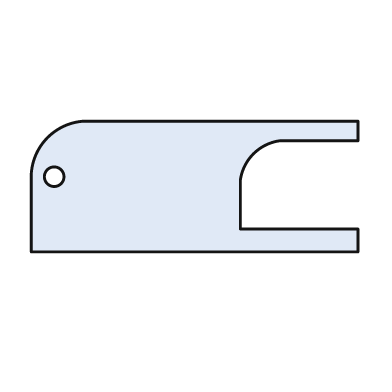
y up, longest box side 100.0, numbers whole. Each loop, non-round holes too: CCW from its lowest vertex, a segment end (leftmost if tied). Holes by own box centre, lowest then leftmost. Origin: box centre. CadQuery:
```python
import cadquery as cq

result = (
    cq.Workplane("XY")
    .moveTo(-50.0, -20.0)
    .lineTo(50.0, -20.0)
    .lineTo(50.0, -13.0)
    .lineTo(14.0, -13.0)
    .lineTo(14.0, 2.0)
    .threePointArc((18.0, 10.0), (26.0, 14.0))
    .lineTo(50.0, 14.0)
    .lineTo(50.0, 20.0)
    .lineTo(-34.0, 20.0)
    .threePointArc((-45.0, 15.0), (-50.0, 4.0))
    .close()
    .moveTo(-43.0, 3.0)
    .circle(3.0)
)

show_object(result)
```